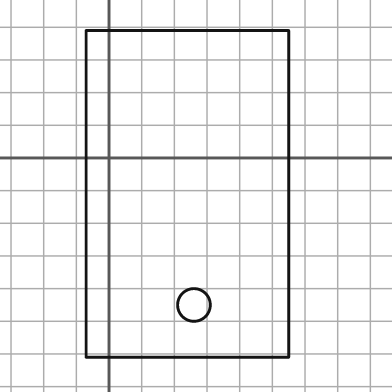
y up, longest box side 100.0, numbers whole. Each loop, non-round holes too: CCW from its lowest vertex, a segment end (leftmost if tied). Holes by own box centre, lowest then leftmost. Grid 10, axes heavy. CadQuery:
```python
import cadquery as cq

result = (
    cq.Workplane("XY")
    .moveTo(-7.0, -61.0)
    .lineTo(55.0, -61.0)
    .lineTo(55.0, 39.0)
    .lineTo(-7.0, 39.0)
    .close()
    .moveTo(26.0, -45.0)
    .circle(5.0)
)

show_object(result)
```